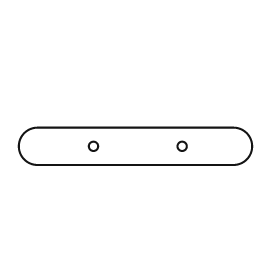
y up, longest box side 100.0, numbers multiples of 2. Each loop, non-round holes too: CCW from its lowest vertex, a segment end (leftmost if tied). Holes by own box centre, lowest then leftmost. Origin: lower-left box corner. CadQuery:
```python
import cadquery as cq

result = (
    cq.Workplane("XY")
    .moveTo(8.0, 0.0)
    .lineTo(92.0, 0.0)
    .threePointArc((100.0, 8.0), (92.0, 16.0))
    .lineTo(8.0, 16.0)
    .threePointArc((0.0, 8.0), (8.0, 0.0))
    .close()
    .moveTo(32.0, 8.0)
    .circle(2.0)
    .moveTo(70.0, 8.0)
    .circle(2.0)
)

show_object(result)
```